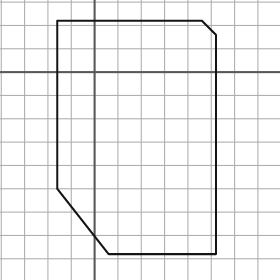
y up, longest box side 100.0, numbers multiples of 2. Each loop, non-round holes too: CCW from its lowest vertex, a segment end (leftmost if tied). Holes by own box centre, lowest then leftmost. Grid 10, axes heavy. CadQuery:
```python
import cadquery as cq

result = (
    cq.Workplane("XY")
    .moveTo(6.0, -78.0)
    .lineTo(52.0, -78.0)
    .lineTo(52.0, 16.0)
    .lineTo(46.0, 22.0)
    .lineTo(-16.0, 22.0)
    .lineTo(-16.0, -50.0)
    .close()
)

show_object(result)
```